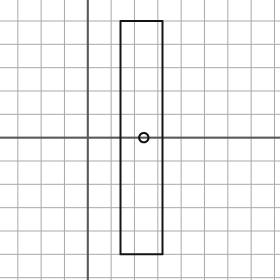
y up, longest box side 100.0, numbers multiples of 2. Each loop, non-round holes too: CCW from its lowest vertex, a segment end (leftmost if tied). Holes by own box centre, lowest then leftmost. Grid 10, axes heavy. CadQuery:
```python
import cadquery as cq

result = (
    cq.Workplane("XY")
    .moveTo(14.0, -50.0)
    .lineTo(32.0, -50.0)
    .lineTo(32.0, 50.0)
    .lineTo(14.0, 50.0)
    .close()
    .moveTo(24.0, 0.0)
    .circle(2.0)
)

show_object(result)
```